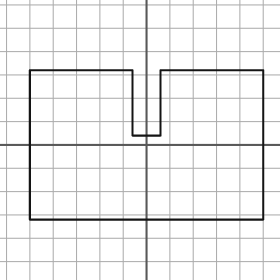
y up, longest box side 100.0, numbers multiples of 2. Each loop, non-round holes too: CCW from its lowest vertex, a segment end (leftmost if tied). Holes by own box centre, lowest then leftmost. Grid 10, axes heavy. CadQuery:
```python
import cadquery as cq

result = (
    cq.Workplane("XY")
    .moveTo(-50.0, -32.0)
    .lineTo(50.0, -32.0)
    .lineTo(50.0, 32.0)
    .lineTo(6.0, 32.0)
    .lineTo(6.0, 4.0)
    .lineTo(-6.0, 4.0)
    .lineTo(-6.0, 32.0)
    .lineTo(-50.0, 32.0)
    .close()
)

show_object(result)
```